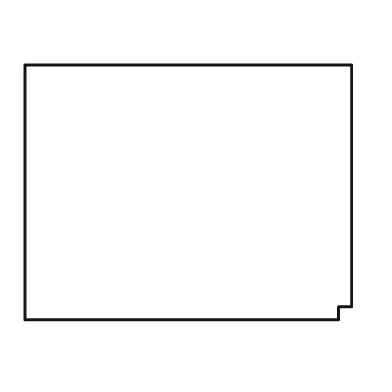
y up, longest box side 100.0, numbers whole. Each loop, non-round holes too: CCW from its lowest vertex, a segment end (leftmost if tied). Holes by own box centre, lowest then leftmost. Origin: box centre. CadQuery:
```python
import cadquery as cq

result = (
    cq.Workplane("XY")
    .moveTo(-50.0, -39.0)
    .lineTo(46.0, -39.0)
    .lineTo(46.0, -35.0)
    .lineTo(50.0, -35.0)
    .lineTo(50.0, 39.0)
    .lineTo(-50.0, 39.0)
    .close()
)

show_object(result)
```